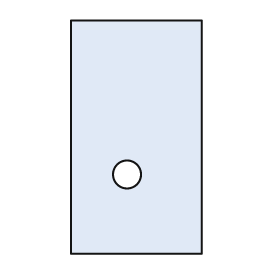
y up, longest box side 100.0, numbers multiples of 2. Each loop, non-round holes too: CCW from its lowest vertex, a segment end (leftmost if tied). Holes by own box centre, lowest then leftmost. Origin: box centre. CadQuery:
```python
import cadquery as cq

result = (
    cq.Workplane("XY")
    .moveTo(-28.0, -50.0)
    .lineTo(28.0, -50.0)
    .lineTo(28.0, 50.0)
    .lineTo(-28.0, 50.0)
    .close()
    .moveTo(-4.0, -16.0)
    .circle(6.0)
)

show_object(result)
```